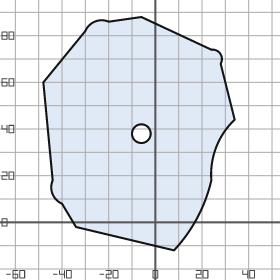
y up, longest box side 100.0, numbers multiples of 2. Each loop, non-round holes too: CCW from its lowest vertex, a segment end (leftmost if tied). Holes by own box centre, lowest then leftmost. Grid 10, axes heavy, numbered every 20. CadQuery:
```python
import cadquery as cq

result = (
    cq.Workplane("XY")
    .moveTo(8.0, -12.0)
    .threePointArc((18.0, 2.0), (24.0, 18.0))
    .threePointArc((26.0, 32.0), (34.0, 44.0))
    .lineTo(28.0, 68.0)
    .threePointArc((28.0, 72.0), (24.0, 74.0))
    .lineTo(-6.0, 88.0)
    .lineTo(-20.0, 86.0)
    .threePointArc((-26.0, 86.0), (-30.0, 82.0))
    .lineTo(-48.0, 60.0)
    .lineTo(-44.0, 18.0)
    .threePointArc((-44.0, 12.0), (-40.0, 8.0))
    .lineTo(-34.0, -2.0)
    .close()
    .moveTo(-6.0, 38.0)
    .circle(4.0)
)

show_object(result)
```